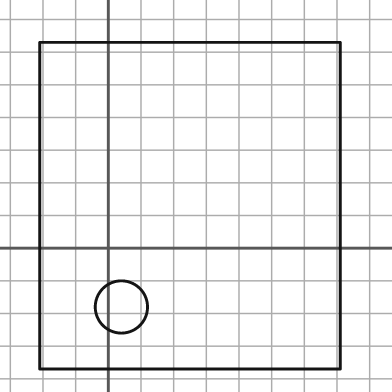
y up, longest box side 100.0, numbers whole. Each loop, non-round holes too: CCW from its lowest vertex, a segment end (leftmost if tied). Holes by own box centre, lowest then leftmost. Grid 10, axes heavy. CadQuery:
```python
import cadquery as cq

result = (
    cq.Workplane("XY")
    .moveTo(-21.0, -37.0)
    .lineTo(71.0, -37.0)
    .lineTo(71.0, 63.0)
    .lineTo(-21.0, 63.0)
    .close()
    .moveTo(4.0, -18.0)
    .circle(8.0)
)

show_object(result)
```